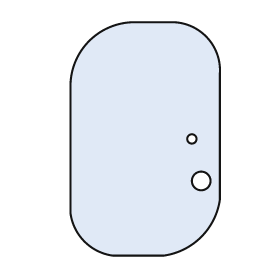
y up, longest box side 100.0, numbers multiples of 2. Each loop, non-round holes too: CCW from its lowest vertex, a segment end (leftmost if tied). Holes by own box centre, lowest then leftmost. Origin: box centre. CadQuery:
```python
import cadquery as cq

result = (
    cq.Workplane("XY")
    .moveTo(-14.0, -50.0)
    .lineTo(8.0, -50.0)
    .threePointArc((24.0, -42.0), (32.0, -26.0))
    .lineTo(32.0, 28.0)
    .threePointArc((26.0, 44.0), (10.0, 50.0))
    .lineTo(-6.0, 50.0)
    .threePointArc((-24.0, 42.0), (-32.0, 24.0))
    .lineTo(-32.0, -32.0)
    .threePointArc((-26.0, -44.0), (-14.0, -50.0))
    .close()
    .moveTo(24.0, -18.0)
    .circle(4.0)
    .moveTo(20.0, 0.0)
    .circle(2.0)
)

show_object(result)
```